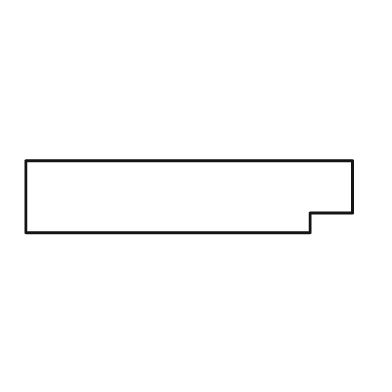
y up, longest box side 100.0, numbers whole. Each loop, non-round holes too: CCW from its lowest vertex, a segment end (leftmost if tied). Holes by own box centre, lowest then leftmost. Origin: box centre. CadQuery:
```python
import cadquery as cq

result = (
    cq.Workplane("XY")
    .moveTo(-50.0, -11.0)
    .lineTo(37.0, -11.0)
    .lineTo(37.0, -5.0)
    .lineTo(50.0, -5.0)
    .lineTo(50.0, 11.0)
    .lineTo(-50.0, 11.0)
    .close()
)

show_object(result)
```